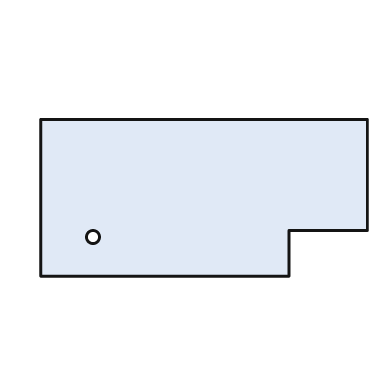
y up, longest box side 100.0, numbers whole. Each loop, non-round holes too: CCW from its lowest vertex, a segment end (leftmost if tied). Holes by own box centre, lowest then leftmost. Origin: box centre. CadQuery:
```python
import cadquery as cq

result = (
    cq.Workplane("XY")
    .moveTo(-50.0, -24.0)
    .lineTo(26.0, -24.0)
    .lineTo(26.0, -10.0)
    .lineTo(50.0, -10.0)
    .lineTo(50.0, 24.0)
    .lineTo(-50.0, 24.0)
    .close()
    .moveTo(-34.0, -12.0)
    .circle(2.0)
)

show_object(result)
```